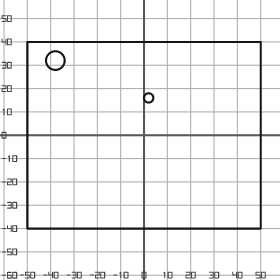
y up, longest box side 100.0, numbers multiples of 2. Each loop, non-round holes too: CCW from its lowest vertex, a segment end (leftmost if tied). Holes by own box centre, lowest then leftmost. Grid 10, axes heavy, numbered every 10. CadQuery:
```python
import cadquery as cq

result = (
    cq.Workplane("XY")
    .moveTo(-50.0, -40.0)
    .lineTo(50.0, -40.0)
    .lineTo(50.0, 40.0)
    .lineTo(-50.0, 40.0)
    .close()
    .moveTo(2.0, 16.0)
    .circle(2.0)
    .moveTo(-38.0, 32.0)
    .circle(4.0)
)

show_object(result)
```